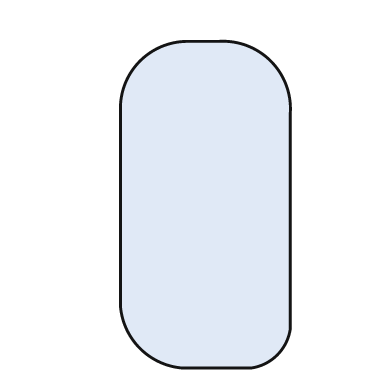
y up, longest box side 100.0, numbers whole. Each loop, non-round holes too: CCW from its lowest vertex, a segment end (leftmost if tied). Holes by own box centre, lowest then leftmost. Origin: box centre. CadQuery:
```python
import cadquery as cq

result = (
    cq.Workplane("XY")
    .moveTo(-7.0, -50.0)
    .lineTo(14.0, -50.0)
    .threePointArc((22.0, -46.0), (26.0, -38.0))
    .lineTo(26.0, 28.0)
    .threePointArc((20.0, 44.0), (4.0, 50.0))
    .lineTo(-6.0, 50.0)
    .threePointArc((-20.0, 44.0), (-26.0, 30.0))
    .lineTo(-26.0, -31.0)
    .threePointArc((-20.0, -44.0), (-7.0, -50.0))
    .close()
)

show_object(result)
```